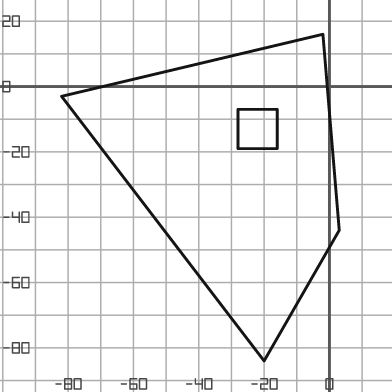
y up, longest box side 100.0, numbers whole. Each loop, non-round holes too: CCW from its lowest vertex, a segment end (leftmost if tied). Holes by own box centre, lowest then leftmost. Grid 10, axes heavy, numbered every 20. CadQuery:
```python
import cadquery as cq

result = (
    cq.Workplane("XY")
    .moveTo(-20.0, -84.0)
    .lineTo(3.0, -44.0)
    .lineTo(-2.0, 16.0)
    .lineTo(-82.0, -3.0)
    .close()
    .moveTo(-28.0, -19.0)
    .lineTo(-16.0, -19.0)
    .lineTo(-16.0, -7.0)
    .lineTo(-28.0, -7.0)
    .close()
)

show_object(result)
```